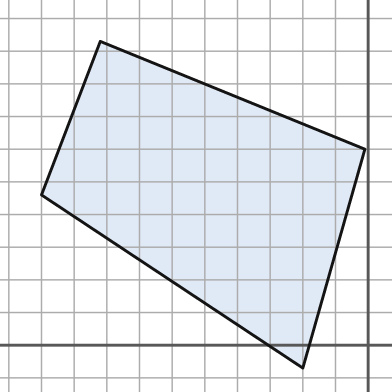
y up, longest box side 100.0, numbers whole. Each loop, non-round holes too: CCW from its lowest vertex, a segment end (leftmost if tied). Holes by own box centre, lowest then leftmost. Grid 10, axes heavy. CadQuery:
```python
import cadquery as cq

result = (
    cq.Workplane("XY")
    .moveTo(-20.0, -7.0)
    .lineTo(-1.0, 60.0)
    .lineTo(-82.0, 93.0)
    .lineTo(-100.0, 46.0)
    .close()
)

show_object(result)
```